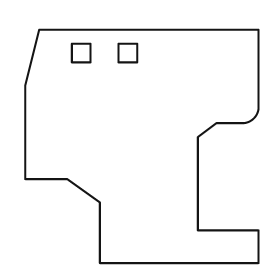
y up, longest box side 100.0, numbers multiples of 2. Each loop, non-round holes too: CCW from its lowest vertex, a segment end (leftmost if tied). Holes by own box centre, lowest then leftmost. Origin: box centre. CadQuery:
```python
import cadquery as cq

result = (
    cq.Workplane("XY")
    .moveTo(-18.0, -50.0)
    .lineTo(50.0, -50.0)
    .lineTo(50.0, -36.0)
    .lineTo(24.0, -36.0)
    .lineTo(24.0, 4.0)
    .lineTo(32.0, 10.0)
    .lineTo(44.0, 10.0)
    .threePointArc((48.0, 12.0), (50.0, 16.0))
    .lineTo(50.0, 50.0)
    .lineTo(-44.0, 50.0)
    .lineTo(-50.0, 26.0)
    .lineTo(-50.0, -14.0)
    .lineTo(-32.0, -14.0)
    .lineTo(-18.0, -24.0)
    .close()
    .moveTo(-30.0, 36.0)
    .lineTo(-22.0, 36.0)
    .lineTo(-22.0, 44.0)
    .lineTo(-30.0, 44.0)
    .close()
    .moveTo(-10.0, 36.0)
    .lineTo(-2.0, 36.0)
    .lineTo(-2.0, 44.0)
    .lineTo(-10.0, 44.0)
    .close()
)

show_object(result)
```